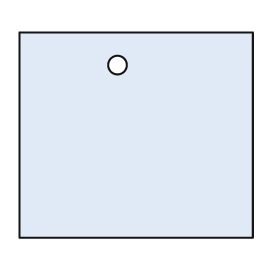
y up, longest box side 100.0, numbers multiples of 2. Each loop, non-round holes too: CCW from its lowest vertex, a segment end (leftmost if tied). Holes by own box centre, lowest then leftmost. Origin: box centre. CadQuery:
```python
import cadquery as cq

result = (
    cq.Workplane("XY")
    .moveTo(-50.0, -44.0)
    .lineTo(50.0, -44.0)
    .lineTo(50.0, 44.0)
    .lineTo(-50.0, 44.0)
    .close()
    .moveTo(-8.0, 30.0)
    .circle(4.0)
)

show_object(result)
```